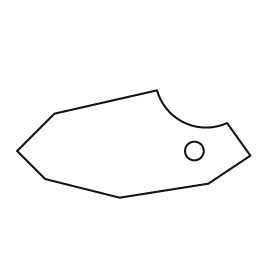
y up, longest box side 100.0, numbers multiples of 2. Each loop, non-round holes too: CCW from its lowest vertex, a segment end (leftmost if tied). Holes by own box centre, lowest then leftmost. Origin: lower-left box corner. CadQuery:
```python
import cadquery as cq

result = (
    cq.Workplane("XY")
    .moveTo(44.0, 0.0)
    .lineTo(82.0, 6.0)
    .lineTo(100.0, 18.0)
    .lineTo(90.0, 32.0)
    .threePointArc((72.0, 32.0), (60.0, 46.0))
    .lineTo(16.0, 36.0)
    .lineTo(0.0, 20.0)
    .lineTo(12.0, 8.0)
    .close()
    .moveTo(76.0, 20.0)
    .circle(4.0)
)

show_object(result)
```